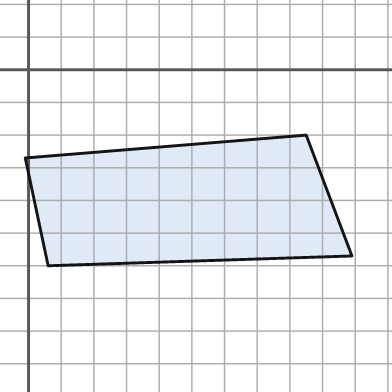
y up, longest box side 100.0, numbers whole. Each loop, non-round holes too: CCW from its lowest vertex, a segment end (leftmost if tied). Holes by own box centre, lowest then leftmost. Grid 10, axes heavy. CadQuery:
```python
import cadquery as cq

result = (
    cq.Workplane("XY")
    .moveTo(6.0, -60.0)
    .lineTo(99.0, -57.0)
    .lineTo(85.0, -20.0)
    .lineTo(-1.0, -27.0)
    .close()
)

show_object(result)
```